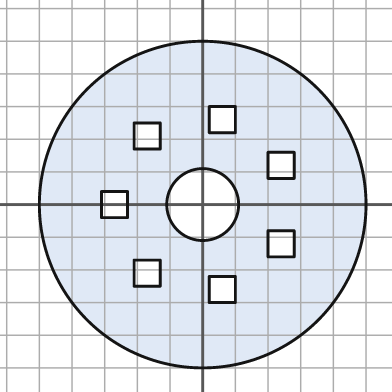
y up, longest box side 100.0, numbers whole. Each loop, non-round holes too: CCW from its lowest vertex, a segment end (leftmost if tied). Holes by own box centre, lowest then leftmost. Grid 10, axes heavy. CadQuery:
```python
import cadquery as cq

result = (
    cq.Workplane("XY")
    .moveTo(0.0, 0.0)
    .circle(50.0)
    .moveTo(2.0, -30.0)
    .lineTo(10.0, -30.0)
    .lineTo(10.0, -22.0)
    .lineTo(2.0, -22.0)
    .close()
    .moveTo(-21.0, -25.0)
    .lineTo(-13.0, -25.0)
    .lineTo(-13.0, -17.0)
    .lineTo(-21.0, -17.0)
    .close()
    .moveTo(20.0, -16.0)
    .lineTo(28.0, -16.0)
    .lineTo(28.0, -8.0)
    .lineTo(20.0, -8.0)
    .close()
    .moveTo(-31.0, -4.0)
    .lineTo(-23.0, -4.0)
    .lineTo(-23.0, 4.0)
    .lineTo(-31.0, 4.0)
    .close()
    .moveTo(0.0, 0.0)
    .circle(11.0)
    .moveTo(20.0, 8.0)
    .lineTo(28.0, 8.0)
    .lineTo(28.0, 16.0)
    .lineTo(20.0, 16.0)
    .close()
    .moveTo(-21.0, 17.0)
    .lineTo(-13.0, 17.0)
    .lineTo(-13.0, 25.0)
    .lineTo(-21.0, 25.0)
    .close()
    .moveTo(2.0, 22.0)
    .lineTo(10.0, 22.0)
    .lineTo(10.0, 30.0)
    .lineTo(2.0, 30.0)
    .close()
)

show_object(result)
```